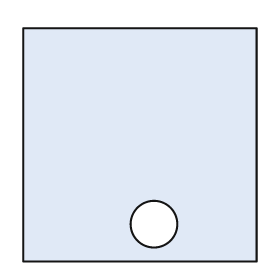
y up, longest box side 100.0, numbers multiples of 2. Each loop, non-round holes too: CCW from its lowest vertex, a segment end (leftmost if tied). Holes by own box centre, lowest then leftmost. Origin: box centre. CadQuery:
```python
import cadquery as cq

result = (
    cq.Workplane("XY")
    .moveTo(-50.0, -50.0)
    .lineTo(50.0, -50.0)
    .lineTo(50.0, 50.0)
    .lineTo(-50.0, 50.0)
    .close()
    .moveTo(6.0, -34.0)
    .circle(10.0)
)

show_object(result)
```